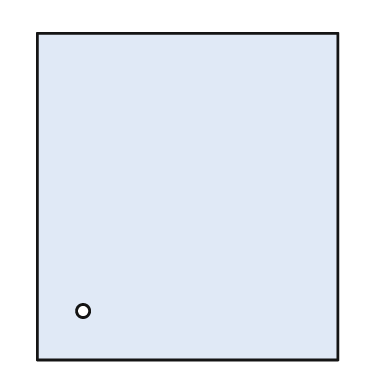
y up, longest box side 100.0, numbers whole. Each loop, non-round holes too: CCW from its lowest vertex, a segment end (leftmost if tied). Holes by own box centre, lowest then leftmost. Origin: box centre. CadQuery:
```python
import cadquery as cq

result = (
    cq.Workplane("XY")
    .moveTo(-46.0, -50.0)
    .lineTo(46.0, -50.0)
    .lineTo(46.0, 50.0)
    .lineTo(-46.0, 50.0)
    .close()
    .moveTo(-32.0, -35.0)
    .circle(2.0)
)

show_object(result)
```